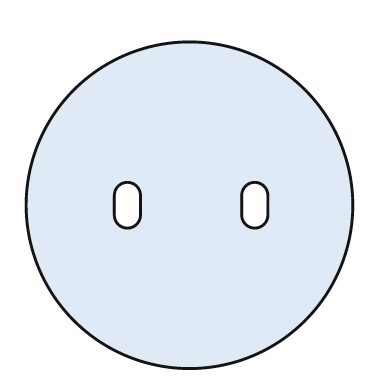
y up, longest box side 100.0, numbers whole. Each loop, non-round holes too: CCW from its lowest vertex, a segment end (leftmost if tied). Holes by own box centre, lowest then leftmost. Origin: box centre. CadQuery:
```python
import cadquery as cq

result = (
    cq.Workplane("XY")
    .moveTo(0.0, 0.0)
    .circle(50.0)
    .moveTo(-23.0, -3.0)
    .threePointArc((-19.0, -7.0), (-15.0, -3.0))
    .lineTo(-15.0, 3.0)
    .threePointArc((-19.0, 7.0), (-23.0, 3.0))
    .close()
    .moveTo(16.0, -3.0)
    .threePointArc((20.0, -7.0), (24.0, -3.0))
    .lineTo(24.0, 3.0)
    .threePointArc((20.0, 7.0), (16.0, 3.0))
    .close()
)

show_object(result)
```